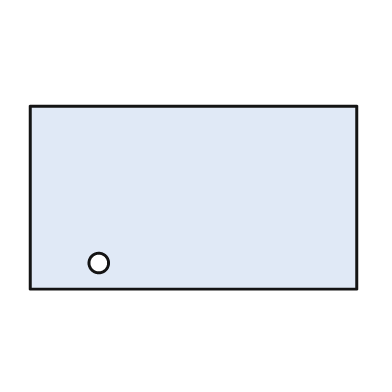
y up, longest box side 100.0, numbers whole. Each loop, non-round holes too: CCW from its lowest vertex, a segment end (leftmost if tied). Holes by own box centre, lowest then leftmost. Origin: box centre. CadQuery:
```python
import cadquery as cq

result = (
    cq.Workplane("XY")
    .moveTo(-50.0, -28.0)
    .lineTo(50.0, -28.0)
    .lineTo(50.0, 28.0)
    .lineTo(-50.0, 28.0)
    .close()
    .moveTo(-29.0, -20.0)
    .circle(3.0)
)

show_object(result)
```